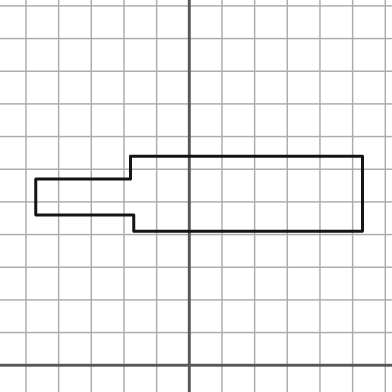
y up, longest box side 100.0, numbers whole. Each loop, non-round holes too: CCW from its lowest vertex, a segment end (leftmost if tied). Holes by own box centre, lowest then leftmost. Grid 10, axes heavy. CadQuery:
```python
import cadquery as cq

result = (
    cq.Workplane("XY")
    .moveTo(-17.0, 41.0)
    .lineTo(53.0, 41.0)
    .lineTo(53.0, 64.0)
    .lineTo(-18.0, 64.0)
    .lineTo(-18.0, 57.0)
    .lineTo(-47.0, 57.0)
    .lineTo(-47.0, 46.0)
    .lineTo(-17.0, 46.0)
    .close()
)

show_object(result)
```